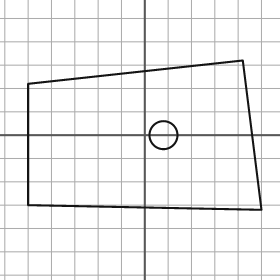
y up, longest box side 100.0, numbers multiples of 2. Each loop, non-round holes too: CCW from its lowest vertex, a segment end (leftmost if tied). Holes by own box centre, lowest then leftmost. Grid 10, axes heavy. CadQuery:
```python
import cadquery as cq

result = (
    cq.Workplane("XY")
    .moveTo(50.0, -32.0)
    .lineTo(42.0, 32.0)
    .lineTo(-50.0, 22.0)
    .lineTo(-50.0, -30.0)
    .close()
    .moveTo(8.0, 0.0)
    .circle(6.0)
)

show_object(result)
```